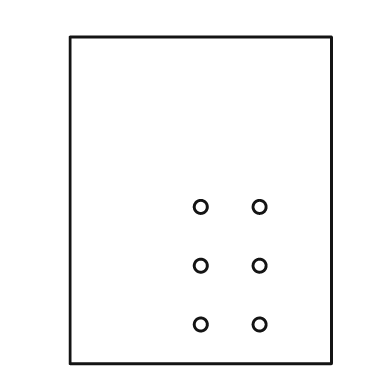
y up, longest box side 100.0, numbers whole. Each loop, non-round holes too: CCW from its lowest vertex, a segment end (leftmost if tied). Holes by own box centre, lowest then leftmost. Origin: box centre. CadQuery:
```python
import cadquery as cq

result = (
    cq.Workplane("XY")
    .moveTo(-40.0, -50.0)
    .lineTo(40.0, -50.0)
    .lineTo(40.0, 50.0)
    .lineTo(-40.0, 50.0)
    .close()
    .moveTo(0.0, -38.0)
    .circle(2.0)
    .moveTo(18.0, -38.0)
    .circle(2.0)
    .moveTo(0.0, -20.0)
    .circle(2.0)
    .moveTo(18.0, -20.0)
    .circle(2.0)
    .moveTo(0.0, -2.0)
    .circle(2.0)
    .moveTo(18.0, -2.0)
    .circle(2.0)
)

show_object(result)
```